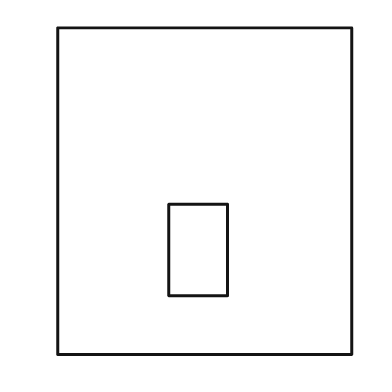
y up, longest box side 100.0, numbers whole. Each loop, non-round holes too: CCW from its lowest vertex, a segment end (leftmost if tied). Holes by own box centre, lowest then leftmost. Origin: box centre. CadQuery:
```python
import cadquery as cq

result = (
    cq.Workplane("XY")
    .moveTo(-45.0, -50.0)
    .lineTo(45.0, -50.0)
    .lineTo(45.0, 50.0)
    .lineTo(-45.0, 50.0)
    .close()
    .moveTo(-11.0, -32.0)
    .lineTo(7.0, -32.0)
    .lineTo(7.0, -4.0)
    .lineTo(-11.0, -4.0)
    .close()
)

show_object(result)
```